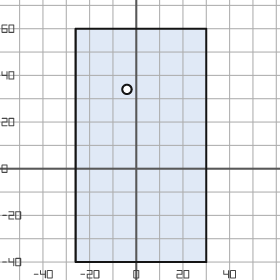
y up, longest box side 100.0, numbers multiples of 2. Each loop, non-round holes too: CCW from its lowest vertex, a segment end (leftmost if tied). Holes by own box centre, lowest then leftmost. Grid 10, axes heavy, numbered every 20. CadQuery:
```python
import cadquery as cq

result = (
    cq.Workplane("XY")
    .moveTo(-26.0, -40.0)
    .lineTo(30.0, -40.0)
    .lineTo(30.0, 60.0)
    .lineTo(-26.0, 60.0)
    .close()
    .moveTo(-4.0, 34.0)
    .circle(2.0)
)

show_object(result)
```